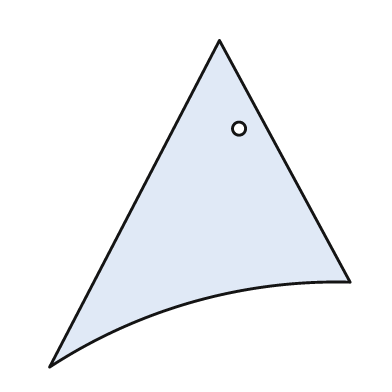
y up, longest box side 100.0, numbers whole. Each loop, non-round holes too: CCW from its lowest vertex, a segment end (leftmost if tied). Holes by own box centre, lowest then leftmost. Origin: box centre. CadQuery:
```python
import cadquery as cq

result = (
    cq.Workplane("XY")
    .moveTo(-46.0, -50.0)
    .threePointArc((-2.0, -30.0), (46.0, -24.0))
    .lineTo(6.0, 50.0)
    .close()
    .moveTo(12.0, 23.0)
    .circle(2.0)
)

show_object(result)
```